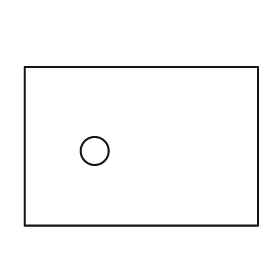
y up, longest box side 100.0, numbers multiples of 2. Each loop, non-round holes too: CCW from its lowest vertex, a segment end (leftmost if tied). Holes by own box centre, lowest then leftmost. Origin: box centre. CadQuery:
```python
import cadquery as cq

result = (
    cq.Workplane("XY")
    .moveTo(-50.0, -34.0)
    .lineTo(50.0, -34.0)
    .lineTo(50.0, 34.0)
    .lineTo(-50.0, 34.0)
    .close()
    .moveTo(-20.0, -2.0)
    .circle(6.0)
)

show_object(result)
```